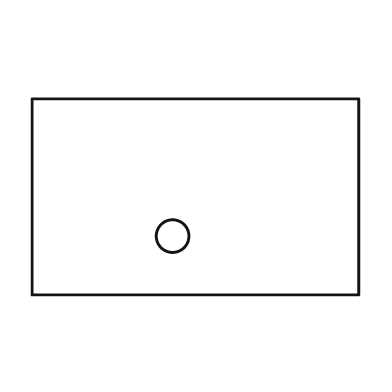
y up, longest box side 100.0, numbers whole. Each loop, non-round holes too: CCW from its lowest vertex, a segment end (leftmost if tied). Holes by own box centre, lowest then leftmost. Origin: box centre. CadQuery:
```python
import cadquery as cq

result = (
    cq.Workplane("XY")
    .moveTo(-50.0, -30.0)
    .lineTo(50.0, -30.0)
    .lineTo(50.0, 30.0)
    .lineTo(-50.0, 30.0)
    .close()
    .moveTo(-7.0, -12.0)
    .circle(5.0)
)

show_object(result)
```